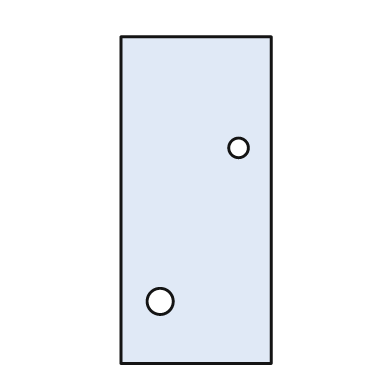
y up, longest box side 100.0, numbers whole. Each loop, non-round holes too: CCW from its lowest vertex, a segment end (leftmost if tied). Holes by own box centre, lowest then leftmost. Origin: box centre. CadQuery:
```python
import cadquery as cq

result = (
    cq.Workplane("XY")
    .moveTo(-23.0, -50.0)
    .lineTo(23.0, -50.0)
    .lineTo(23.0, 50.0)
    .lineTo(-23.0, 50.0)
    .close()
    .moveTo(-11.0, -31.0)
    .circle(4.0)
    .moveTo(13.0, 16.0)
    .circle(3.0)
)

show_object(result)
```